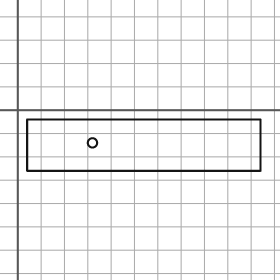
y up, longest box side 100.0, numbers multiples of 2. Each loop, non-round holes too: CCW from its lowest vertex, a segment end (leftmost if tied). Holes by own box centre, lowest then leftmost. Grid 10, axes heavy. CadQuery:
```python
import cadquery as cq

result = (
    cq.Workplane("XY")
    .moveTo(4.0, -26.0)
    .lineTo(104.0, -26.0)
    .lineTo(104.0, -4.0)
    .lineTo(4.0, -4.0)
    .close()
    .moveTo(32.0, -14.0)
    .circle(2.0)
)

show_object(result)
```